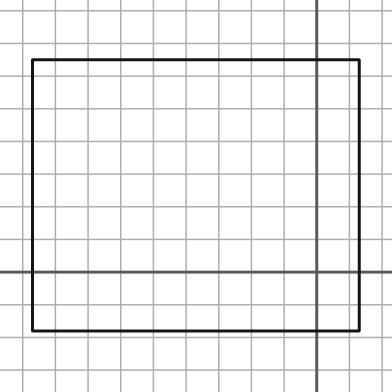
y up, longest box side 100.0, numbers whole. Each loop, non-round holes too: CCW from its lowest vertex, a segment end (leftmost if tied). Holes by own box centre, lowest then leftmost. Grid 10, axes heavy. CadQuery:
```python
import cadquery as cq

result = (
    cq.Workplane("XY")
    .moveTo(-87.0, -18.0)
    .lineTo(13.0, -18.0)
    .lineTo(13.0, 65.0)
    .lineTo(-87.0, 65.0)
    .close()
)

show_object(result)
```